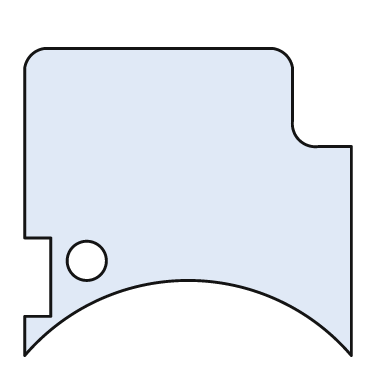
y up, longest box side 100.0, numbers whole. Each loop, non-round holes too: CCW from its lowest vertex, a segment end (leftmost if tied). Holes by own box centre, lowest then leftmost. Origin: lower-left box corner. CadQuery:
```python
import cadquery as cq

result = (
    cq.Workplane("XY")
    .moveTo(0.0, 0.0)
    .threePointArc((50.0, 23.0), (100.0, 0.0))
    .lineTo(100.0, 64.0)
    .lineTo(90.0, 64.0)
    .threePointArc((84.0, 66.0), (82.0, 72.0))
    .lineTo(82.0, 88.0)
    .threePointArc((80.0, 92.0), (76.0, 94.0))
    .lineTo(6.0, 94.0)
    .threePointArc((2.0, 92.0), (0.0, 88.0))
    .lineTo(0.0, 36.0)
    .lineTo(8.0, 36.0)
    .lineTo(8.0, 12.0)
    .lineTo(0.0, 12.0)
    .close()
    .moveTo(19.0, 29.0)
    .circle(6.0)
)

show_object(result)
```